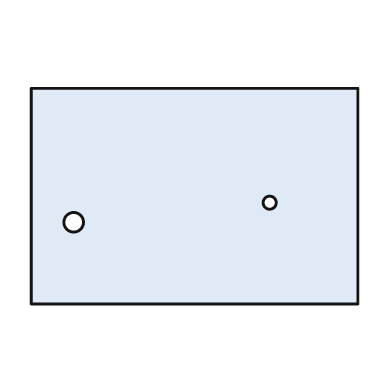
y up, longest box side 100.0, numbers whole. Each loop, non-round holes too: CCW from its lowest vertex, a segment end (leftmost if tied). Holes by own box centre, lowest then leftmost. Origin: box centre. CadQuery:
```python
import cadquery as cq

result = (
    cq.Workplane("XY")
    .moveTo(-50.0, -33.0)
    .lineTo(50.0, -33.0)
    .lineTo(50.0, 33.0)
    .lineTo(-50.0, 33.0)
    .close()
    .moveTo(-37.0, -8.0)
    .circle(3.0)
    .moveTo(23.0, -2.0)
    .circle(2.0)
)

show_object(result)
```